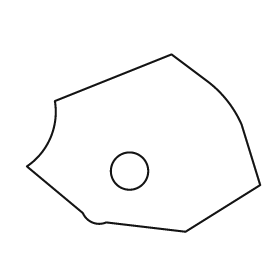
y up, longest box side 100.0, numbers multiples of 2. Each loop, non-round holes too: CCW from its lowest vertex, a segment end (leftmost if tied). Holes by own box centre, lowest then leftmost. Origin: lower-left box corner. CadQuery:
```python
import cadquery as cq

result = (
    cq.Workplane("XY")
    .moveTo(68.0, 0.0)
    .lineTo(100.0, 20.0)
    .lineTo(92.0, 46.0)
    .threePointArc((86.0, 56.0), (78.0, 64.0))
    .lineTo(62.0, 76.0)
    .lineTo(12.0, 56.0)
    .threePointArc((10.0, 40.0), (0.0, 28.0))
    .lineTo(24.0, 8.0)
    .threePointArc((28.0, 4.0), (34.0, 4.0))
    .close()
    .moveTo(44.0, 26.0)
    .circle(8.0)
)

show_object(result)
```